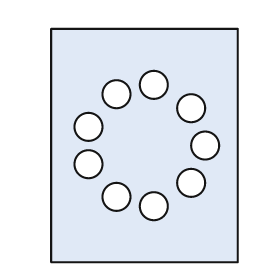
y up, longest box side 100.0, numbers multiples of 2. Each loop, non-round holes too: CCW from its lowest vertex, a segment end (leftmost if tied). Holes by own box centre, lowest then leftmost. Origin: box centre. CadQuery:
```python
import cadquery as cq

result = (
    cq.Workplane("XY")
    .moveTo(-40.0, -50.0)
    .lineTo(40.0, -50.0)
    .lineTo(40.0, 50.0)
    .lineTo(-40.0, 50.0)
    .close()
    .moveTo(4.0, -26.0)
    .circle(6.0)
    .moveTo(-12.0, -22.0)
    .circle(6.0)
    .moveTo(20.0, -16.0)
    .circle(6.0)
    .moveTo(-24.0, -8.0)
    .circle(6.0)
    .moveTo(26.0, 0.0)
    .circle(6.0)
    .moveTo(-24.0, 8.0)
    .circle(6.0)
    .moveTo(20.0, 16.0)
    .circle(6.0)
    .moveTo(-12.0, 22.0)
    .circle(6.0)
    .moveTo(4.0, 26.0)
    .circle(6.0)
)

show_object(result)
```